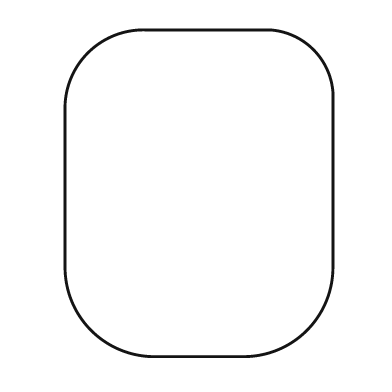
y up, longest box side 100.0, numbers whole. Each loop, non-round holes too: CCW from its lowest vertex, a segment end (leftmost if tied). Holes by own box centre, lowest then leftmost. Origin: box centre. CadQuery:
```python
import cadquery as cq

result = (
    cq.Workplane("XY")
    .moveTo(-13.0, -50.0)
    .lineTo(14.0, -50.0)
    .threePointArc((33.0, -42.0), (41.0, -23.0))
    .lineTo(41.0, 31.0)
    .threePointArc((35.0, 44.0), (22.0, 50.0))
    .lineTo(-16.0, 50.0)
    .threePointArc((-34.0, 43.0), (-41.0, 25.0))
    .lineTo(-41.0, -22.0)
    .threePointArc((-33.0, -42.0), (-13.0, -50.0))
    .close()
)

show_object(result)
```